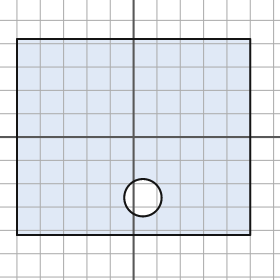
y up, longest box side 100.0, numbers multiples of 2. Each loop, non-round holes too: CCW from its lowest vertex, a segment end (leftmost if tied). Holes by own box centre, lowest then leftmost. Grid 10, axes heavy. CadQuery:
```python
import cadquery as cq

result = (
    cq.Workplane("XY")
    .moveTo(-50.0, -42.0)
    .lineTo(50.0, -42.0)
    .lineTo(50.0, 42.0)
    .lineTo(-50.0, 42.0)
    .close()
    .moveTo(4.0, -26.0)
    .circle(8.0)
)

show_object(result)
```